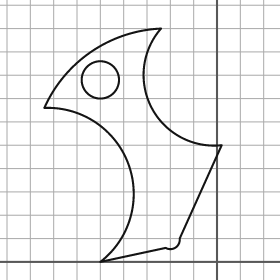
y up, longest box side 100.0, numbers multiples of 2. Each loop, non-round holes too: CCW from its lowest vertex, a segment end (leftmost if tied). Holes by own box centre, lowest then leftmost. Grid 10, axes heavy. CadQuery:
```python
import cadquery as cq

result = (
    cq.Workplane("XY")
    .moveTo(-50.0, 0.0)
    .lineTo(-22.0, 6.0)
    .threePointArc((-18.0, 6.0), (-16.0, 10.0))
    .lineTo(2.0, 50.0)
    .threePointArc((-28.0, 66.0), (-24.0, 100.0))
    .threePointArc((-54.0, 90.0), (-74.0, 66.0))
    .threePointArc((-38.0, 42.0), (-50.0, 0.0))
    .close()
    .moveTo(-50.0, 78.0)
    .circle(8.0)
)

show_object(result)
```